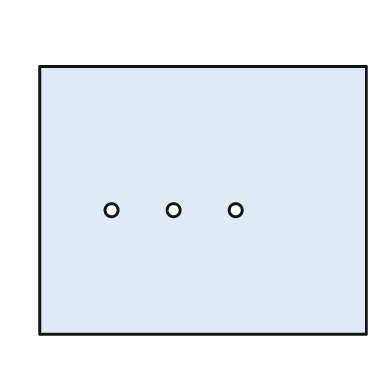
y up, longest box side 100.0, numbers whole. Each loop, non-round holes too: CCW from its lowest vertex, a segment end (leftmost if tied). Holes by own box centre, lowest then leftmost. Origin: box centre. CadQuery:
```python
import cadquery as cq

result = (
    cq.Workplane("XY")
    .moveTo(-50.0, -41.0)
    .lineTo(50.0, -41.0)
    .lineTo(50.0, 41.0)
    .lineTo(-50.0, 41.0)
    .close()
    .moveTo(-28.0, -3.0)
    .circle(2.0)
    .moveTo(-9.0, -3.0)
    .circle(2.0)
    .moveTo(10.0, -3.0)
    .circle(2.0)
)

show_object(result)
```